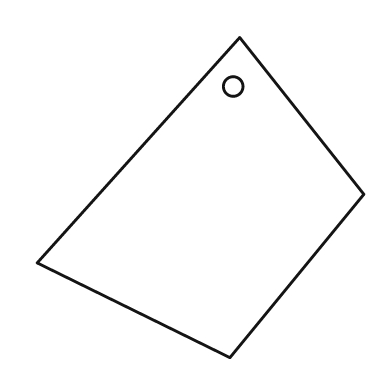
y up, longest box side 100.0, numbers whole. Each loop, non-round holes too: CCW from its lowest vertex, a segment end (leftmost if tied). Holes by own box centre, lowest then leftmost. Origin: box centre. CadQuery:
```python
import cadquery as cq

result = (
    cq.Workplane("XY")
    .moveTo(9.0, -49.0)
    .lineTo(50.0, 1.0)
    .lineTo(12.0, 49.0)
    .lineTo(-50.0, -20.0)
    .close()
    .moveTo(10.0, 34.0)
    .circle(3.0)
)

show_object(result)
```